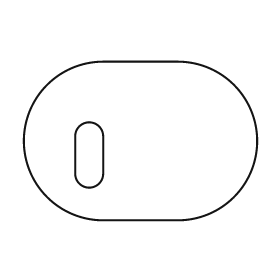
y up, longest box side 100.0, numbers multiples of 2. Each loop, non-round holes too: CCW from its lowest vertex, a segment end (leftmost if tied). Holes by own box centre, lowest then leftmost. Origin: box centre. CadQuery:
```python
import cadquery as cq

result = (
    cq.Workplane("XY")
    .moveTo(-16.0, -34.0)
    .lineTo(16.0, -34.0)
    .threePointArc((50.0, 0.0), (16.0, 34.0))
    .lineTo(-16.0, 34.0)
    .threePointArc((-50.0, 0.0), (-16.0, -34.0))
    .close()
    .moveTo(-28.0, -14.0)
    .threePointArc((-22.0, -20.0), (-16.0, -14.0))
    .lineTo(-16.0, 2.0)
    .threePointArc((-22.0, 8.0), (-28.0, 2.0))
    .close()
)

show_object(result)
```